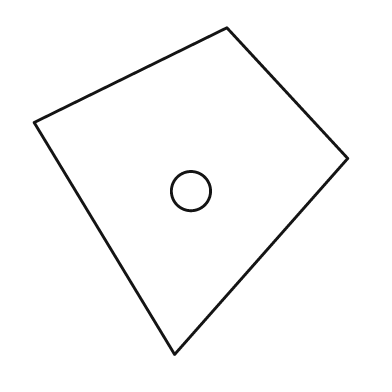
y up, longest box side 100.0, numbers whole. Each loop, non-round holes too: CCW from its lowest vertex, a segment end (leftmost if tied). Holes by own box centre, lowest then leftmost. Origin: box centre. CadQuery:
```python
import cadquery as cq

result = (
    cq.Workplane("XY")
    .moveTo(-5.0, -50.0)
    .lineTo(48.0, 10.0)
    .lineTo(11.0, 50.0)
    .lineTo(-48.0, 21.0)
    .close()
    .moveTo(0.0, 0.0)
    .circle(6.0)
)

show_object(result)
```